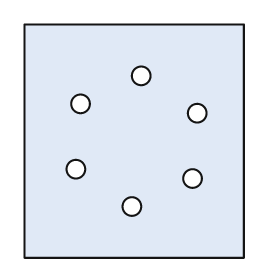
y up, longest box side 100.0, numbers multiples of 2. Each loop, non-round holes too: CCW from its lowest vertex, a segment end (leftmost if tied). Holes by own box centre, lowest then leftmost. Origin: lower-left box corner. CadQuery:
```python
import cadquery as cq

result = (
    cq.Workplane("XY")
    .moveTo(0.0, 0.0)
    .lineTo(94.0, 0.0)
    .lineTo(94.0, 100.0)
    .lineTo(0.0, 100.0)
    .close()
    .moveTo(46.0, 22.0)
    .circle(4.0)
    .moveTo(72.0, 34.0)
    .circle(4.0)
    .moveTo(22.0, 38.0)
    .circle(4.0)
    .moveTo(74.0, 62.0)
    .circle(4.0)
    .moveTo(24.0, 66.0)
    .circle(4.0)
    .moveTo(50.0, 78.0)
    .circle(4.0)
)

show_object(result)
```